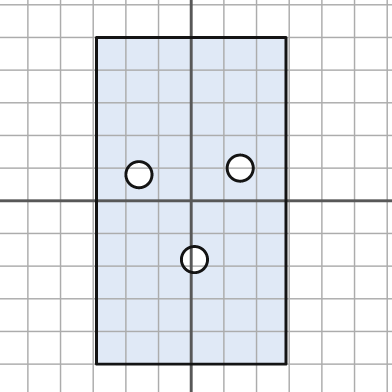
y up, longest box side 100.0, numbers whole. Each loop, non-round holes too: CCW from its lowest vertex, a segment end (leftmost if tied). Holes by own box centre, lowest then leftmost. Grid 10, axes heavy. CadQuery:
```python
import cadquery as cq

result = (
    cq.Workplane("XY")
    .moveTo(-29.0, -50.0)
    .lineTo(29.0, -50.0)
    .lineTo(29.0, 50.0)
    .lineTo(-29.0, 50.0)
    .close()
    .moveTo(1.0, -18.0)
    .circle(4.0)
    .moveTo(-16.0, 8.0)
    .circle(4.0)
    .moveTo(15.0, 10.0)
    .circle(4.0)
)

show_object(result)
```